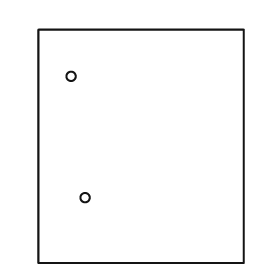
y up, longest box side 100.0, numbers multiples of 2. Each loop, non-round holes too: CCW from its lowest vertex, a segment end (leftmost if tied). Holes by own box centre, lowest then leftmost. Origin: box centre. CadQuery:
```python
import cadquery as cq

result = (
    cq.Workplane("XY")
    .moveTo(-44.0, -50.0)
    .lineTo(44.0, -50.0)
    .lineTo(44.0, 50.0)
    .lineTo(-44.0, 50.0)
    .close()
    .moveTo(-24.0, -22.0)
    .circle(2.0)
    .moveTo(-30.0, 30.0)
    .circle(2.0)
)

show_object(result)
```